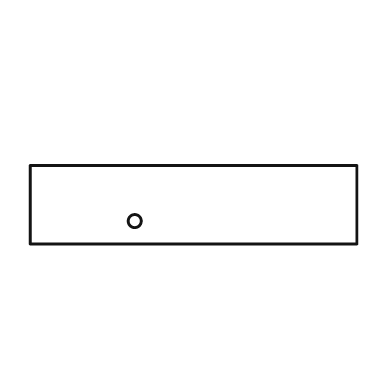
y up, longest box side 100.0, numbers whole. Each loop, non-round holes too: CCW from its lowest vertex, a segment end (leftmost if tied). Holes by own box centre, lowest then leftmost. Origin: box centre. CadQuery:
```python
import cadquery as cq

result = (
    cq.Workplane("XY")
    .moveTo(-50.0, -12.0)
    .lineTo(50.0, -12.0)
    .lineTo(50.0, 12.0)
    .lineTo(-50.0, 12.0)
    .close()
    .moveTo(-18.0, -5.0)
    .circle(2.0)
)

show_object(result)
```